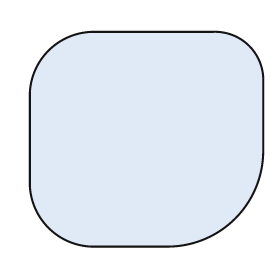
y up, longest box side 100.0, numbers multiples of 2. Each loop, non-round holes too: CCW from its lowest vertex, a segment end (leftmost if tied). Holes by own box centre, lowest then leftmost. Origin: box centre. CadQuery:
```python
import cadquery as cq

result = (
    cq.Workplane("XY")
    .moveTo(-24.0, -46.0)
    .lineTo(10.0, -46.0)
    .threePointArc((38.0, -34.0), (50.0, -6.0))
    .lineTo(50.0, 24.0)
    .threePointArc((44.0, 40.0), (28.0, 46.0))
    .lineTo(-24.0, 46.0)
    .threePointArc((-42.0, 38.0), (-50.0, 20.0))
    .lineTo(-50.0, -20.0)
    .threePointArc((-42.0, -38.0), (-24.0, -46.0))
    .close()
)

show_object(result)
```